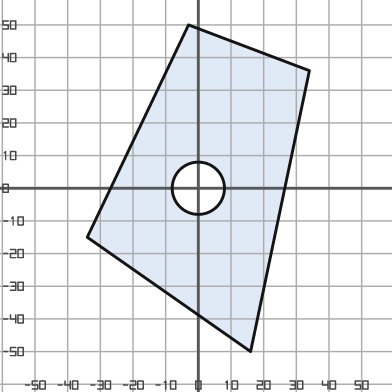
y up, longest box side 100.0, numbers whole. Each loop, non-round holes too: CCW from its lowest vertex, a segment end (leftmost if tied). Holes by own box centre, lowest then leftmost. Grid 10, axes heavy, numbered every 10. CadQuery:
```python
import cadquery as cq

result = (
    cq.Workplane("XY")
    .moveTo(16.0, -50.0)
    .lineTo(34.0, 36.0)
    .lineTo(-3.0, 50.0)
    .lineTo(-34.0, -15.0)
    .close()
    .moveTo(0.0, 0.0)
    .circle(8.0)
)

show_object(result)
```